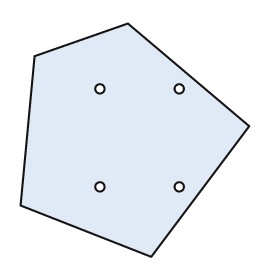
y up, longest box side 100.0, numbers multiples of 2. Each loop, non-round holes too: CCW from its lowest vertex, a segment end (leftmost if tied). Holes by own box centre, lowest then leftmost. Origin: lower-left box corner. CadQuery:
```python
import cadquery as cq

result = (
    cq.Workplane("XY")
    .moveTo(56.0, 0.0)
    .lineTo(98.0, 56.0)
    .lineTo(46.0, 100.0)
    .lineTo(6.0, 86.0)
    .lineTo(0.0, 22.0)
    .close()
    .moveTo(34.0, 30.0)
    .circle(2.0)
    .moveTo(68.0, 30.0)
    .circle(2.0)
    .moveTo(34.0, 72.0)
    .circle(2.0)
    .moveTo(68.0, 72.0)
    .circle(2.0)
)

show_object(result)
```